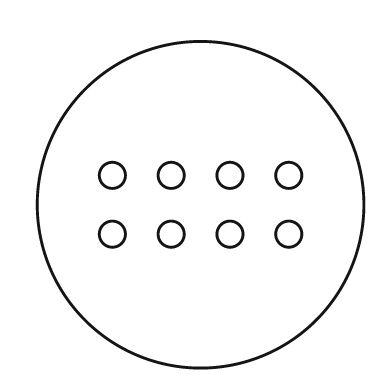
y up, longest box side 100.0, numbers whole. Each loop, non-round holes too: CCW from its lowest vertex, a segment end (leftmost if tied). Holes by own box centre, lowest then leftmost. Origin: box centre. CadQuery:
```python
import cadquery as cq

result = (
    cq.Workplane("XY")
    .moveTo(0.0, 0.0)
    .circle(50.0)
    .moveTo(-27.0, -9.0)
    .circle(4.0)
    .moveTo(-9.0, -9.0)
    .circle(4.0)
    .moveTo(9.0, -9.0)
    .circle(4.0)
    .moveTo(27.0, -9.0)
    .circle(4.0)
    .moveTo(-27.0, 9.0)
    .circle(4.0)
    .moveTo(-9.0, 9.0)
    .circle(4.0)
    .moveTo(9.0, 9.0)
    .circle(4.0)
    .moveTo(27.0, 9.0)
    .circle(4.0)
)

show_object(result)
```